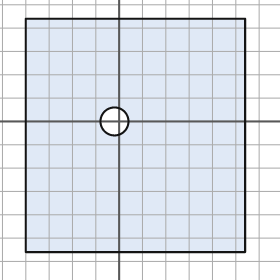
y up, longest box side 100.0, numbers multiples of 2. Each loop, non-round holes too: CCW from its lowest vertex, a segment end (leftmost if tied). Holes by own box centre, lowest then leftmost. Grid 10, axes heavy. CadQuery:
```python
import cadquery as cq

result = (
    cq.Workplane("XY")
    .moveTo(-40.0, -56.0)
    .lineTo(54.0, -56.0)
    .lineTo(54.0, 44.0)
    .lineTo(-40.0, 44.0)
    .close()
    .moveTo(-2.0, 0.0)
    .circle(6.0)
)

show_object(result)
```